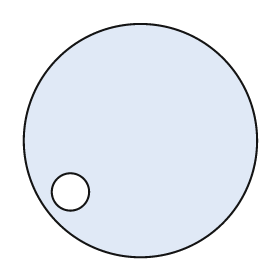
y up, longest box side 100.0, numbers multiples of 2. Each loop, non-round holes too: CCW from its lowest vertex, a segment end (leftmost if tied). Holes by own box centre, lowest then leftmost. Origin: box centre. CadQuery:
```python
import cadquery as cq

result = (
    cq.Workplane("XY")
    .moveTo(0.0, 0.0)
    .circle(50.0)
    .moveTo(-30.0, -22.0)
    .circle(8.0)
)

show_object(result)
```